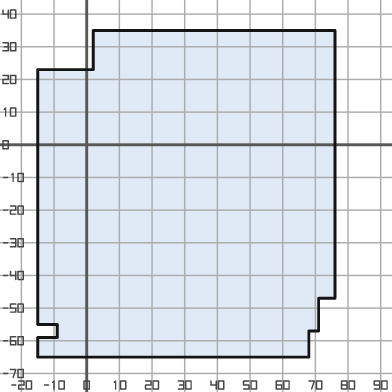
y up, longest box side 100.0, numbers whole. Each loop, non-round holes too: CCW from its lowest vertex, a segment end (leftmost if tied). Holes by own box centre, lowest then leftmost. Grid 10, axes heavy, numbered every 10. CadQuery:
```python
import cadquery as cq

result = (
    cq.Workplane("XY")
    .moveTo(-15.0, -65.0)
    .lineTo(68.0, -65.0)
    .lineTo(68.0, -57.0)
    .lineTo(71.0, -57.0)
    .lineTo(71.0, -47.0)
    .lineTo(76.0, -47.0)
    .lineTo(76.0, 35.0)
    .lineTo(2.0, 35.0)
    .lineTo(2.0, 23.0)
    .lineTo(-15.0, 23.0)
    .lineTo(-15.0, -55.0)
    .lineTo(-9.0, -55.0)
    .lineTo(-9.0, -59.0)
    .lineTo(-15.0, -59.0)
    .close()
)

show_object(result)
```